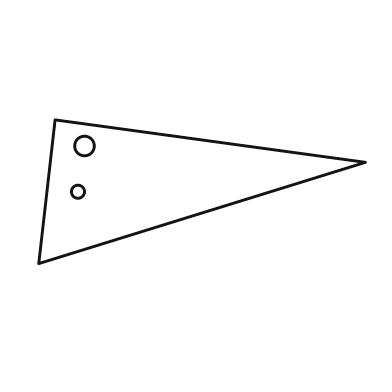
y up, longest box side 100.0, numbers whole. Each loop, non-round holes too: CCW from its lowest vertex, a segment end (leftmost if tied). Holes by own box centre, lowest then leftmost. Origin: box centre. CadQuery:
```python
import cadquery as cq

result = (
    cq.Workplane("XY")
    .moveTo(-50.0, -22.0)
    .lineTo(50.0, 9.0)
    .lineTo(-45.0, 22.0)
    .close()
    .moveTo(-38.0, 0.0)
    .circle(2.0)
    .moveTo(-36.0, 14.0)
    .circle(3.0)
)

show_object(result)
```